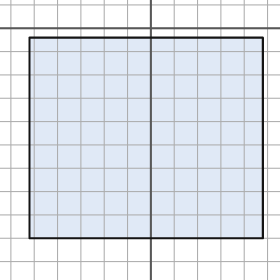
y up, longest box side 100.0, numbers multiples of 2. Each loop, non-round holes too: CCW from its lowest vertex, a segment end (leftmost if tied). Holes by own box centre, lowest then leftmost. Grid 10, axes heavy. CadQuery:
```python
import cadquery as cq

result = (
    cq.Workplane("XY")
    .moveTo(-52.0, -90.0)
    .lineTo(48.0, -90.0)
    .lineTo(48.0, -4.0)
    .lineTo(-52.0, -4.0)
    .close()
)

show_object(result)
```